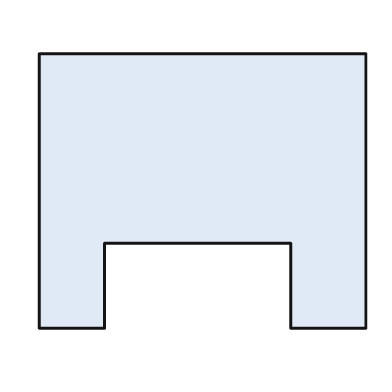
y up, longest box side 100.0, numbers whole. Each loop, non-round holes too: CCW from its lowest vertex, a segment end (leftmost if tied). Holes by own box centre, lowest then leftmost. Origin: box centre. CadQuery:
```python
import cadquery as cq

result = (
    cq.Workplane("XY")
    .moveTo(-50.0, -42.0)
    .lineTo(-30.0, -42.0)
    .lineTo(-30.0, -16.0)
    .lineTo(27.0, -16.0)
    .lineTo(27.0, -42.0)
    .lineTo(50.0, -42.0)
    .lineTo(50.0, 42.0)
    .lineTo(-50.0, 42.0)
    .close()
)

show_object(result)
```